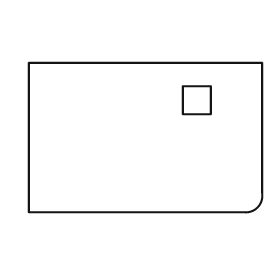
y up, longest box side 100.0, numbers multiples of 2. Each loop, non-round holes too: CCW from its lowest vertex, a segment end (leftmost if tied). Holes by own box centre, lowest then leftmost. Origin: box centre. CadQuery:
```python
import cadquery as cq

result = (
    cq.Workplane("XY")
    .moveTo(-50.0, -32.0)
    .lineTo(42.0, -32.0)
    .threePointArc((48.0, -30.0), (50.0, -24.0))
    .lineTo(50.0, 32.0)
    .lineTo(-50.0, 32.0)
    .close()
    .moveTo(16.0, 10.0)
    .lineTo(28.0, 10.0)
    .lineTo(28.0, 22.0)
    .lineTo(16.0, 22.0)
    .close()
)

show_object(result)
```